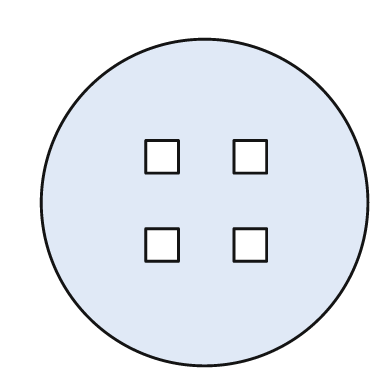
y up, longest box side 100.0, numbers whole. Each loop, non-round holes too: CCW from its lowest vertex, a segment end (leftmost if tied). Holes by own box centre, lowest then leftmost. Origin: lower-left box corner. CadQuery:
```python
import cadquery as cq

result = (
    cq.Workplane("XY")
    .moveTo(50.0, 50.0)
    .circle(50.0)
    .moveTo(32.0, 32.0)
    .lineTo(42.0, 32.0)
    .lineTo(42.0, 42.0)
    .lineTo(32.0, 42.0)
    .close()
    .moveTo(59.0, 32.0)
    .lineTo(69.0, 32.0)
    .lineTo(69.0, 42.0)
    .lineTo(59.0, 42.0)
    .close()
    .moveTo(32.0, 59.0)
    .lineTo(42.0, 59.0)
    .lineTo(42.0, 69.0)
    .lineTo(32.0, 69.0)
    .close()
    .moveTo(59.0, 59.0)
    .lineTo(69.0, 59.0)
    .lineTo(69.0, 69.0)
    .lineTo(59.0, 69.0)
    .close()
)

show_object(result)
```